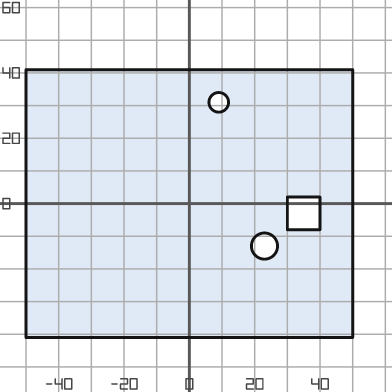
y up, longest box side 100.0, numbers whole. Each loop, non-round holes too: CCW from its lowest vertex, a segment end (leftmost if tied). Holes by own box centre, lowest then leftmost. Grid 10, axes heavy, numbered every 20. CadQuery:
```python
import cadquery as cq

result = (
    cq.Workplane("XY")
    .moveTo(-50.0, -41.0)
    .lineTo(50.0, -41.0)
    .lineTo(50.0, 41.0)
    .lineTo(-50.0, 41.0)
    .close()
    .moveTo(23.0, -13.0)
    .circle(4.0)
    .moveTo(30.0, -8.0)
    .lineTo(40.0, -8.0)
    .lineTo(40.0, 2.0)
    .lineTo(30.0, 2.0)
    .close()
    .moveTo(9.0, 31.0)
    .circle(3.0)
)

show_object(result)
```